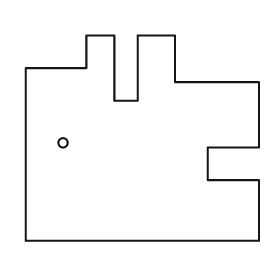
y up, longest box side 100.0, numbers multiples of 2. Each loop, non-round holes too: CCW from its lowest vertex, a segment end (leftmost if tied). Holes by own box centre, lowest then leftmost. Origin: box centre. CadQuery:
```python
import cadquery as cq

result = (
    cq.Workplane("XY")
    .moveTo(-50.0, -44.0)
    .lineTo(50.0, -44.0)
    .lineTo(50.0, -18.0)
    .lineTo(28.0, -18.0)
    .lineTo(28.0, -4.0)
    .lineTo(50.0, -4.0)
    .lineTo(50.0, 24.0)
    .lineTo(14.0, 24.0)
    .lineTo(14.0, 44.0)
    .lineTo(-2.0, 44.0)
    .lineTo(-2.0, 16.0)
    .lineTo(-12.0, 16.0)
    .lineTo(-12.0, 44.0)
    .lineTo(-24.0, 44.0)
    .lineTo(-24.0, 30.0)
    .lineTo(-50.0, 30.0)
    .close()
    .moveTo(-34.0, -2.0)
    .circle(2.0)
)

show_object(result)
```